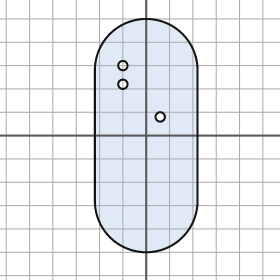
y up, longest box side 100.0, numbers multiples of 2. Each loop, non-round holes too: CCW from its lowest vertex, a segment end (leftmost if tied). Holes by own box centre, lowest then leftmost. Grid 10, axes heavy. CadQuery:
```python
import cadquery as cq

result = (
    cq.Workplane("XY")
    .moveTo(-22.0, -28.0)
    .threePointArc((0.0, -50.0), (22.0, -28.0))
    .lineTo(22.0, 28.0)
    .threePointArc((0.0, 50.0), (-22.0, 28.0))
    .close()
    .moveTo(6.0, 8.0)
    .circle(2.0)
    .moveTo(-10.0, 22.0)
    .circle(2.0)
    .moveTo(-10.0, 30.0)
    .circle(2.0)
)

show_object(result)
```